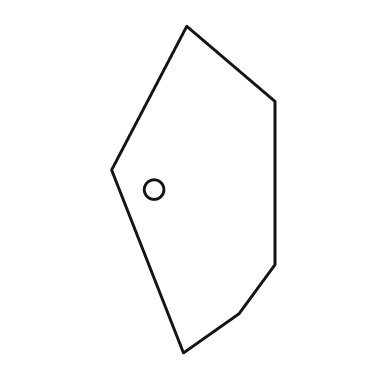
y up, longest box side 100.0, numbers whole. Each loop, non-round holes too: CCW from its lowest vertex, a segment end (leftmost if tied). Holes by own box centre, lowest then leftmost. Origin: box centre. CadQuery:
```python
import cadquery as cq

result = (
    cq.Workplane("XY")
    .moveTo(-3.0, -50.0)
    .lineTo(14.0, -38.0)
    .lineTo(25.0, -23.0)
    .lineTo(25.0, 27.0)
    .lineTo(-2.0, 50.0)
    .lineTo(-25.0, 6.0)
    .close()
    .moveTo(-12.0, 0.0)
    .circle(3.0)
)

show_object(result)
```